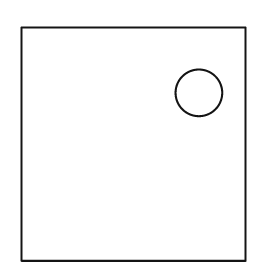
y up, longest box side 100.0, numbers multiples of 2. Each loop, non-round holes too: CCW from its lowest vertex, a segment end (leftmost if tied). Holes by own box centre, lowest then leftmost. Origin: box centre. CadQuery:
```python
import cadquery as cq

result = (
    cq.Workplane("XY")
    .moveTo(-48.0, -50.0)
    .lineTo(48.0, -50.0)
    .lineTo(48.0, 50.0)
    .lineTo(-48.0, 50.0)
    .close()
    .moveTo(28.0, 22.0)
    .circle(10.0)
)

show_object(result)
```